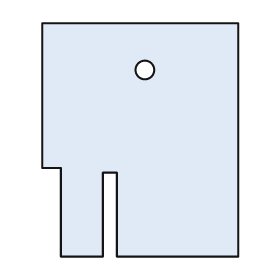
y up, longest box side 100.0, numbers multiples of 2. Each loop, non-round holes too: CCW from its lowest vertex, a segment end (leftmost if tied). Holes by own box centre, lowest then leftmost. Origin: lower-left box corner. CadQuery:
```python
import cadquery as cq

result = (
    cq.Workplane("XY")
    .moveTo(8.0, 0.0)
    .lineTo(26.0, 0.0)
    .lineTo(26.0, 36.0)
    .lineTo(32.0, 36.0)
    .lineTo(32.0, 0.0)
    .lineTo(84.0, 0.0)
    .lineTo(84.0, 100.0)
    .lineTo(0.0, 100.0)
    .lineTo(0.0, 38.0)
    .lineTo(8.0, 38.0)
    .close()
    .moveTo(44.0, 80.0)
    .circle(4.0)
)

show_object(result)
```